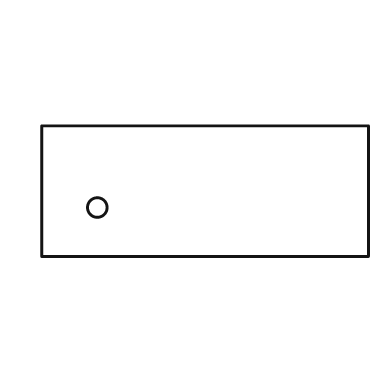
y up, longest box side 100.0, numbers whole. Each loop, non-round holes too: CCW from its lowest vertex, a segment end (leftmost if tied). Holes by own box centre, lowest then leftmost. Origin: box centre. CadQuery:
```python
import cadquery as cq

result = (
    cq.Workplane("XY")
    .moveTo(-50.0, -20.0)
    .lineTo(50.0, -20.0)
    .lineTo(50.0, 20.0)
    .lineTo(-50.0, 20.0)
    .close()
    .moveTo(-33.0, -5.0)
    .circle(3.0)
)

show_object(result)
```